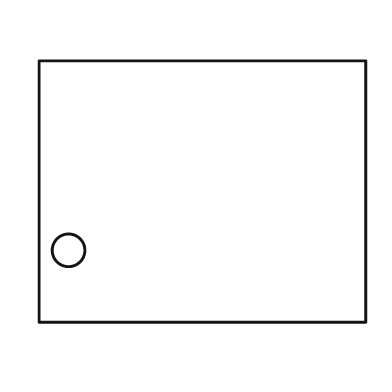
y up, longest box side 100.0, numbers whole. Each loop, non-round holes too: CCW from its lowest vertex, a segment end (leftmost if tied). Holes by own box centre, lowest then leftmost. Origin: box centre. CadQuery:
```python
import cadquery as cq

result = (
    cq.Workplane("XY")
    .moveTo(-50.0, -40.0)
    .lineTo(50.0, -40.0)
    .lineTo(50.0, 40.0)
    .lineTo(-50.0, 40.0)
    .close()
    .moveTo(-41.0, -18.0)
    .circle(5.0)
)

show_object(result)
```